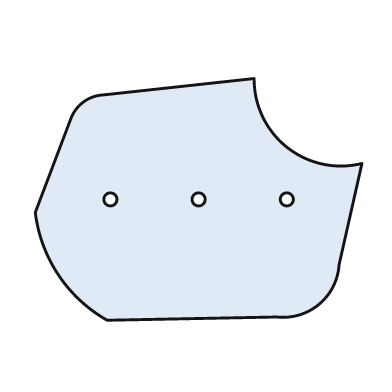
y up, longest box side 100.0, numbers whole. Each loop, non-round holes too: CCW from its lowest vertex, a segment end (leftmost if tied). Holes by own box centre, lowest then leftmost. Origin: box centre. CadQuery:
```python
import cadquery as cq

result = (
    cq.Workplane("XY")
    .moveTo(-28.0, -37.0)
    .lineTo(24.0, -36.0)
    .threePointArc((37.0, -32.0), (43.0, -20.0))
    .lineTo(50.0, 11.0)
    .threePointArc((27.0, 16.0), (17.0, 37.0))
    .lineTo(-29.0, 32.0)
    .threePointArc((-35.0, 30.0), (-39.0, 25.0))
    .lineTo(-50.0, -4.0)
    .threePointArc((-43.0, -23.0), (-28.0, -37.0))
    .close()
    .moveTo(-27.0, 0.0)
    .circle(2.0)
    .moveTo(0.0, 0.0)
    .circle(2.0)
    .moveTo(27.0, 0.0)
    .circle(2.0)
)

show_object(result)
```